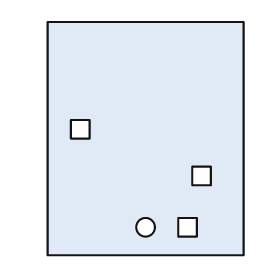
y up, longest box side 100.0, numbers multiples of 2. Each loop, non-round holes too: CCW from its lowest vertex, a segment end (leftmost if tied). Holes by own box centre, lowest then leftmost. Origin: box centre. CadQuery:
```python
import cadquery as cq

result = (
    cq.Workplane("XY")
    .moveTo(-42.0, -50.0)
    .lineTo(42.0, -50.0)
    .lineTo(42.0, 50.0)
    .lineTo(-42.0, 50.0)
    .close()
    .moveTo(0.0, -38.0)
    .circle(4.0)
    .moveTo(14.0, -42.0)
    .lineTo(22.0, -42.0)
    .lineTo(22.0, -34.0)
    .lineTo(14.0, -34.0)
    .close()
    .moveTo(20.0, -20.0)
    .lineTo(28.0, -20.0)
    .lineTo(28.0, -12.0)
    .lineTo(20.0, -12.0)
    .close()
    .moveTo(-32.0, 0.0)
    .lineTo(-24.0, 0.0)
    .lineTo(-24.0, 8.0)
    .lineTo(-32.0, 8.0)
    .close()
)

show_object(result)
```